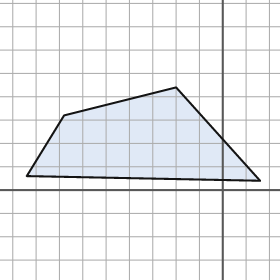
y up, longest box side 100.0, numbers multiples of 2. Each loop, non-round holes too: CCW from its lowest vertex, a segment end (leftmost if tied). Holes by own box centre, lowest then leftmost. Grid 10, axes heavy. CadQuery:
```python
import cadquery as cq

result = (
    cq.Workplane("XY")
    .moveTo(16.0, 4.0)
    .lineTo(-20.0, 44.0)
    .lineTo(-68.0, 32.0)
    .lineTo(-84.0, 6.0)
    .close()
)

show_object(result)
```